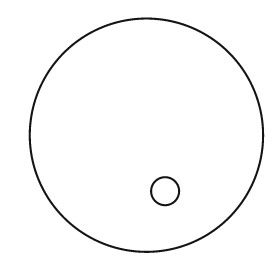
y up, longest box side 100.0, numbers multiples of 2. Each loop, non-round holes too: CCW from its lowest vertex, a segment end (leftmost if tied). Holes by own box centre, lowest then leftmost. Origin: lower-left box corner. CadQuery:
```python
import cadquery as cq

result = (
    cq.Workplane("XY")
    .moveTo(50.0, 50.0)
    .circle(50.0)
    .moveTo(58.0, 26.0)
    .circle(6.0)
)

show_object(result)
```